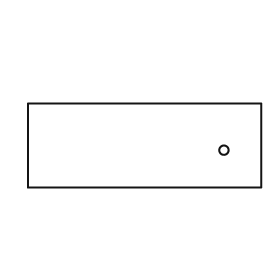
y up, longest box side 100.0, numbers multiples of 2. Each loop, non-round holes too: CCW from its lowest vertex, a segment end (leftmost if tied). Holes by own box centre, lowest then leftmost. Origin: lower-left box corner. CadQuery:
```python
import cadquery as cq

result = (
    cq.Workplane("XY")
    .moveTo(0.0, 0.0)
    .lineTo(100.0, 0.0)
    .lineTo(100.0, 36.0)
    .lineTo(0.0, 36.0)
    .close()
    .moveTo(84.0, 16.0)
    .circle(2.0)
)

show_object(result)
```